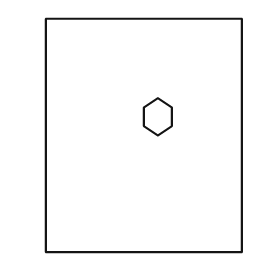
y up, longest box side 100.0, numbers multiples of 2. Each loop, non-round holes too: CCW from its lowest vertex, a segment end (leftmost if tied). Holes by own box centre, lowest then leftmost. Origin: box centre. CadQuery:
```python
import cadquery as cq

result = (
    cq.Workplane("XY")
    .moveTo(-42.0, -50.0)
    .lineTo(42.0, -50.0)
    .lineTo(42.0, 50.0)
    .lineTo(-42.0, 50.0)
    .close()
    .moveTo(6.0, 0.0)
    .lineTo(12.0, 4.0)
    .lineTo(12.0, 12.0)
    .lineTo(6.0, 16.0)
    .lineTo(0.0, 12.0)
    .lineTo(0.0, 4.0)
    .close()
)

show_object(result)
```